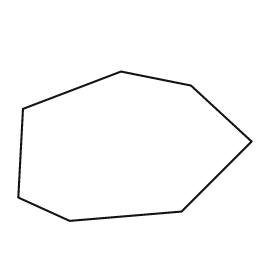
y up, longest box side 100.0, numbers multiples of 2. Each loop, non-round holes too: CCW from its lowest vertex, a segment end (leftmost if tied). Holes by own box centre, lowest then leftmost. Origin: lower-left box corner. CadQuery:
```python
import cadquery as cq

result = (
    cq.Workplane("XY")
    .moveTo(22.0, 0.0)
    .lineTo(70.0, 4.0)
    .lineTo(100.0, 34.0)
    .lineTo(74.0, 58.0)
    .lineTo(44.0, 64.0)
    .lineTo(2.0, 48.0)
    .lineTo(0.0, 10.0)
    .close()
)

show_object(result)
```